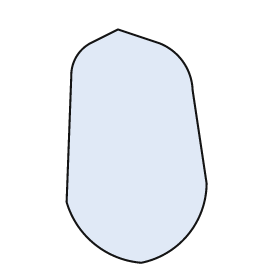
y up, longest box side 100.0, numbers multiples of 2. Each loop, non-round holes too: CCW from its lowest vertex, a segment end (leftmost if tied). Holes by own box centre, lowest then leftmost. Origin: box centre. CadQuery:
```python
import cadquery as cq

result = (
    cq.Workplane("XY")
    .moveTo(2.0, -50.0)
    .threePointArc((22.0, -38.0), (30.0, -16.0))
    .lineTo(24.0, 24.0)
    .threePointArc((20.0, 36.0), (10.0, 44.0))
    .lineTo(-8.0, 50.0)
    .lineTo(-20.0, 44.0)
    .threePointArc((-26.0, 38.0), (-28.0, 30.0))
    .lineTo(-30.0, -24.0)
    .threePointArc((-18.0, -42.0), (2.0, -50.0))
    .close()
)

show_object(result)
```